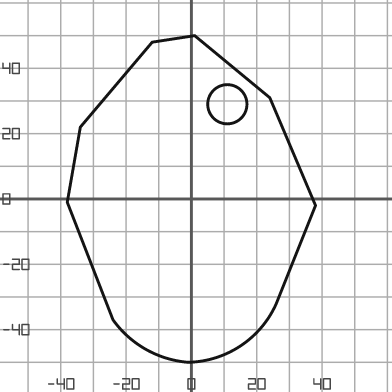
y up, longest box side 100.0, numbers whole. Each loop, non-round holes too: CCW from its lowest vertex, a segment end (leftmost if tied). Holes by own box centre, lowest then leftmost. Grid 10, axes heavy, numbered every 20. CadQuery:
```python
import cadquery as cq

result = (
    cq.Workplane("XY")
    .moveTo(-1.0, -50.0)
    .threePointArc((15.0, -45.0), (26.0, -32.0))
    .lineTo(38.0, -2.0)
    .lineTo(24.0, 31.0)
    .lineTo(1.0, 50.0)
    .lineTo(-12.0, 48.0)
    .lineTo(-34.0, 22.0)
    .lineTo(-38.0, -1.0)
    .lineTo(-24.0, -37.0)
    .threePointArc((-14.0, -46.0), (-1.0, -50.0))
    .close()
    .moveTo(11.0, 29.0)
    .circle(6.0)
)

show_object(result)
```